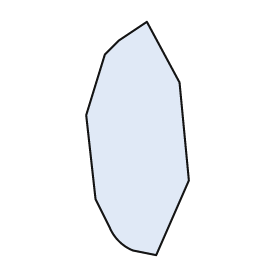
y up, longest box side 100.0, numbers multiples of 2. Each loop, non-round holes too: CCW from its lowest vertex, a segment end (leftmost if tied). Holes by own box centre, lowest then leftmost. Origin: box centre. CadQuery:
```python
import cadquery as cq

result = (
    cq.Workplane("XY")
    .moveTo(8.0, -50.0)
    .lineTo(22.0, -18.0)
    .lineTo(18.0, 24.0)
    .lineTo(4.0, 50.0)
    .lineTo(-8.0, 42.0)
    .lineTo(-14.0, 36.0)
    .lineTo(-22.0, 10.0)
    .lineTo(-18.0, -26.0)
    .lineTo(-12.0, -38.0)
    .threePointArc((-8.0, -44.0), (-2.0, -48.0))
    .close()
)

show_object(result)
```